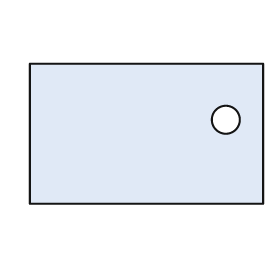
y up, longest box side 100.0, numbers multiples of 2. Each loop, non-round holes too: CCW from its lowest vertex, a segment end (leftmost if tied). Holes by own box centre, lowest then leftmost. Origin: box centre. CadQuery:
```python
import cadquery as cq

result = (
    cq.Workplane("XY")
    .moveTo(-50.0, -30.0)
    .lineTo(50.0, -30.0)
    .lineTo(50.0, 30.0)
    .lineTo(-50.0, 30.0)
    .close()
    .moveTo(34.0, 6.0)
    .circle(6.0)
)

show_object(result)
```